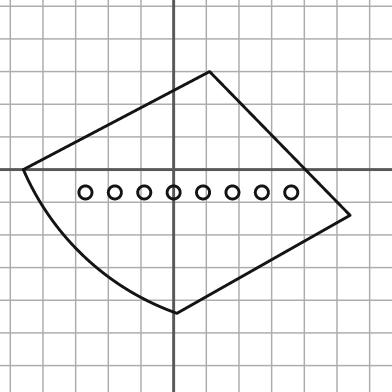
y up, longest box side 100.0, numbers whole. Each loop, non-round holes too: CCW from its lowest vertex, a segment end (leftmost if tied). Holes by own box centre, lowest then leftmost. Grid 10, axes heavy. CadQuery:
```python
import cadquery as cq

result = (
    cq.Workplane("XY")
    .moveTo(1.0, -44.0)
    .lineTo(54.0, -14.0)
    .lineTo(11.0, 30.0)
    .lineTo(-46.0, 0.0)
    .threePointArc((-27.0, -27.0), (1.0, -44.0))
    .close()
    .moveTo(-27.0, -7.0)
    .circle(2.0)
    .moveTo(-18.0, -7.0)
    .circle(2.0)
    .moveTo(-9.0, -7.0)
    .circle(2.0)
    .moveTo(0.0, -7.0)
    .circle(2.0)
    .moveTo(9.0, -7.0)
    .circle(2.0)
    .moveTo(18.0, -7.0)
    .circle(2.0)
    .moveTo(27.0, -7.0)
    .circle(2.0)
    .moveTo(36.0, -7.0)
    .circle(2.0)
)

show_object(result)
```